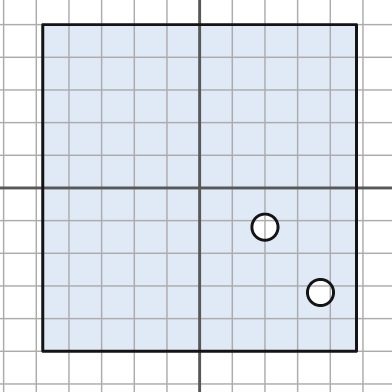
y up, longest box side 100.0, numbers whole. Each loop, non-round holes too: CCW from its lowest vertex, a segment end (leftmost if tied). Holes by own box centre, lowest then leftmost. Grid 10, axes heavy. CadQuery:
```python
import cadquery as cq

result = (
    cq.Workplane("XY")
    .moveTo(-48.0, -50.0)
    .lineTo(48.0, -50.0)
    .lineTo(48.0, 50.0)
    .lineTo(-48.0, 50.0)
    .close()
    .moveTo(37.0, -32.0)
    .circle(4.0)
    .moveTo(20.0, -12.0)
    .circle(4.0)
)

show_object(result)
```